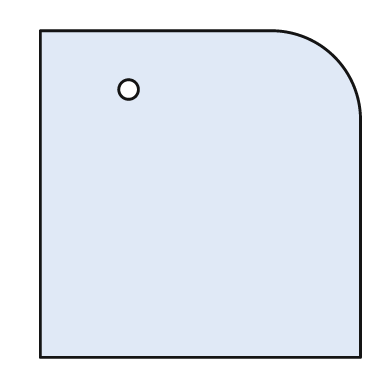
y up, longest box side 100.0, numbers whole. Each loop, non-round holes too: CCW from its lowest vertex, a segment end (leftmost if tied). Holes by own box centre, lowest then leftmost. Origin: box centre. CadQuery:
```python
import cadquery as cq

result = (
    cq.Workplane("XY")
    .moveTo(-49.0, -50.0)
    .lineTo(49.0, -50.0)
    .lineTo(49.0, 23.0)
    .threePointArc((41.0, 42.0), (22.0, 50.0))
    .lineTo(-49.0, 50.0)
    .close()
    .moveTo(-22.0, 32.0)
    .circle(3.0)
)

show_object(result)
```